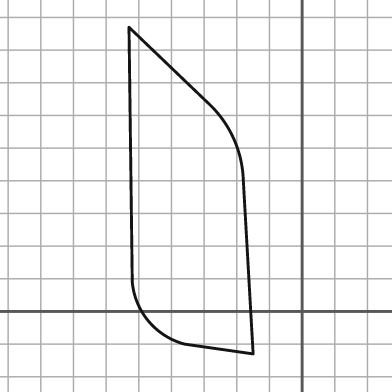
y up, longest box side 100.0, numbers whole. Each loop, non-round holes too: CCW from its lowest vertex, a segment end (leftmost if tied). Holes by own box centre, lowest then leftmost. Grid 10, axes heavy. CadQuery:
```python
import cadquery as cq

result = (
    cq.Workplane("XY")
    .moveTo(-15.0, -13.0)
    .lineTo(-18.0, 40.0)
    .threePointArc((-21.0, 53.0), (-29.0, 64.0))
    .lineTo(-53.0, 87.0)
    .lineTo(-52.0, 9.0)
    .threePointArc((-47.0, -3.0), (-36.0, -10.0))
    .close()
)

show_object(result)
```